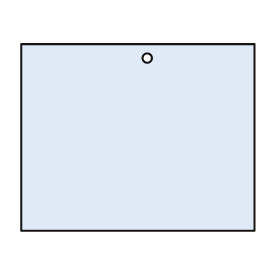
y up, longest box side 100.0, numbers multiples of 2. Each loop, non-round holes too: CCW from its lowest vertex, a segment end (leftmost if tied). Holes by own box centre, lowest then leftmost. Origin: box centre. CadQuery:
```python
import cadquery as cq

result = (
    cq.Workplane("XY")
    .moveTo(-50.0, -40.0)
    .lineTo(50.0, -40.0)
    .lineTo(50.0, 40.0)
    .lineTo(-50.0, 40.0)
    .close()
    .moveTo(4.0, 34.0)
    .circle(2.0)
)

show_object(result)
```